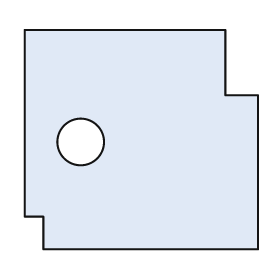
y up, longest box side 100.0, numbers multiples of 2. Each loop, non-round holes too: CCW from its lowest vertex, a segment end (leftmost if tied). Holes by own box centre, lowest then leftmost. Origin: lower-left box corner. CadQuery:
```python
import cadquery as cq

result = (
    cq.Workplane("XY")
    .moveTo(8.0, 0.0)
    .lineTo(100.0, 0.0)
    .lineTo(100.0, 66.0)
    .lineTo(86.0, 66.0)
    .lineTo(86.0, 94.0)
    .lineTo(0.0, 94.0)
    .lineTo(0.0, 14.0)
    .lineTo(8.0, 14.0)
    .close()
    .moveTo(24.0, 46.0)
    .circle(10.0)
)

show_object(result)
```